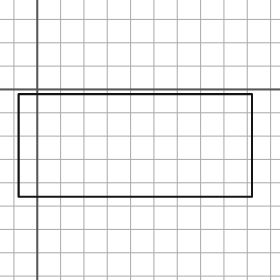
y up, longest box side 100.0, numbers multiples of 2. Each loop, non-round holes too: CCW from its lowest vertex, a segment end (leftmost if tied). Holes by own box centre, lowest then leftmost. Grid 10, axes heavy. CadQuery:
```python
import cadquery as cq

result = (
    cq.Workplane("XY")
    .moveTo(-8.0, -46.0)
    .lineTo(92.0, -46.0)
    .lineTo(92.0, -2.0)
    .lineTo(-8.0, -2.0)
    .close()
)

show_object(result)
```